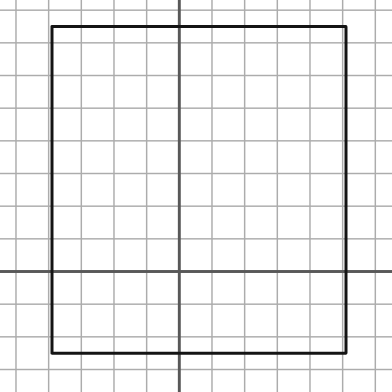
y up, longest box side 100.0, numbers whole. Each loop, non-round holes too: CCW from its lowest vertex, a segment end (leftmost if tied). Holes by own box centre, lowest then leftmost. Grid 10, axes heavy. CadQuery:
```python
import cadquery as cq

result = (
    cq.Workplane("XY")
    .moveTo(-39.0, -25.0)
    .lineTo(51.0, -25.0)
    .lineTo(51.0, 75.0)
    .lineTo(-39.0, 75.0)
    .close()
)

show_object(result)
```